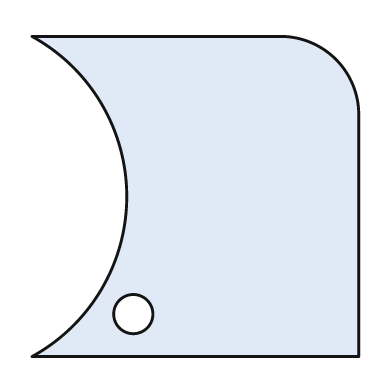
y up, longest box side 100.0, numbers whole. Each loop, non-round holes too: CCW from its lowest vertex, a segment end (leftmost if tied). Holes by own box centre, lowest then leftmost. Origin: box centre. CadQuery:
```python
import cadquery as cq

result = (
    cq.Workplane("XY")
    .moveTo(-50.0, -49.0)
    .lineTo(50.0, -49.0)
    .lineTo(50.0, 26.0)
    .threePointArc((43.0, 42.0), (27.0, 49.0))
    .lineTo(-50.0, 49.0)
    .threePointArc((-21.0, 0.0), (-50.0, -49.0))
    .close()
    .moveTo(-19.0, -36.0)
    .circle(6.0)
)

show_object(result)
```